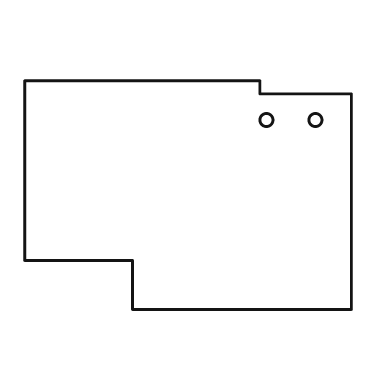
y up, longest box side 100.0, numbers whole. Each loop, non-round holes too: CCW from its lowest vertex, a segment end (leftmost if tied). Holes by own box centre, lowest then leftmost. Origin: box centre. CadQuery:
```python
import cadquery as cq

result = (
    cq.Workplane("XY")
    .moveTo(-17.0, -35.0)
    .lineTo(50.0, -35.0)
    .lineTo(50.0, 31.0)
    .lineTo(22.0, 31.0)
    .lineTo(22.0, 35.0)
    .lineTo(-50.0, 35.0)
    .lineTo(-50.0, -20.0)
    .lineTo(-17.0, -20.0)
    .close()
    .moveTo(24.0, 23.0)
    .circle(2.0)
    .moveTo(39.0, 23.0)
    .circle(2.0)
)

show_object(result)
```